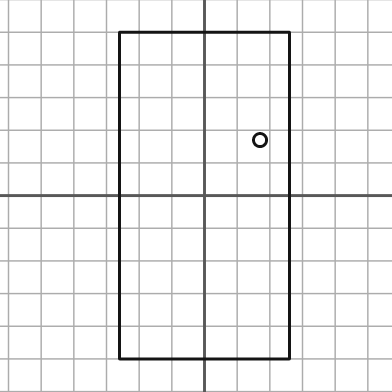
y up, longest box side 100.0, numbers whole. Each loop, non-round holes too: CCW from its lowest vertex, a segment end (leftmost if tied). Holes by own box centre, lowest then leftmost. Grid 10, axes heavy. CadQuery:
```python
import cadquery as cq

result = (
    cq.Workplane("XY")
    .moveTo(-26.0, -50.0)
    .lineTo(26.0, -50.0)
    .lineTo(26.0, 50.0)
    .lineTo(-26.0, 50.0)
    .close()
    .moveTo(17.0, 17.0)
    .circle(2.0)
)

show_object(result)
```